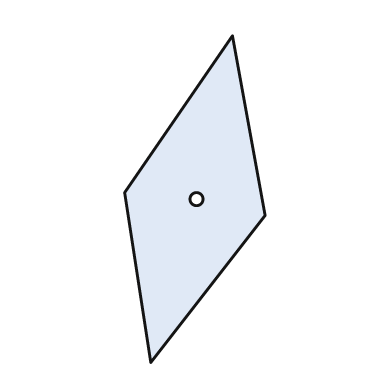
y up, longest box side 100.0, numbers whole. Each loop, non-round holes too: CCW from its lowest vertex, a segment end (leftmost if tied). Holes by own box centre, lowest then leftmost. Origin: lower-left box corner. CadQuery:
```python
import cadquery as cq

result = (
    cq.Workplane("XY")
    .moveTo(8.0, 0.0)
    .lineTo(43.0, 45.0)
    .lineTo(33.0, 100.0)
    .lineTo(0.0, 52.0)
    .close()
    .moveTo(22.0, 50.0)
    .circle(2.0)
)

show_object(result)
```